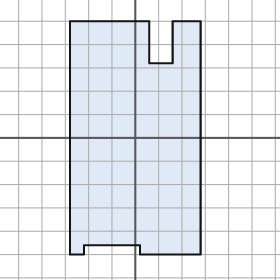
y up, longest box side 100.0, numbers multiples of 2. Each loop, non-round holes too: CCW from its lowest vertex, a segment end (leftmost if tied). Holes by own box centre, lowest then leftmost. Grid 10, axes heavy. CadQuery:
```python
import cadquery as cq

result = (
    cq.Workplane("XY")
    .moveTo(-28.0, -50.0)
    .lineTo(-22.0, -50.0)
    .lineTo(-22.0, -46.0)
    .lineTo(2.0, -46.0)
    .lineTo(2.0, -50.0)
    .lineTo(28.0, -50.0)
    .lineTo(28.0, 50.0)
    .lineTo(16.0, 50.0)
    .lineTo(16.0, 32.0)
    .lineTo(6.0, 32.0)
    .lineTo(6.0, 50.0)
    .lineTo(-28.0, 50.0)
    .close()
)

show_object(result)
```